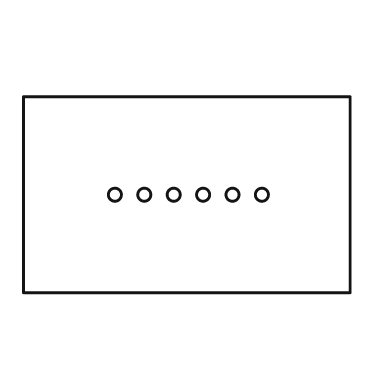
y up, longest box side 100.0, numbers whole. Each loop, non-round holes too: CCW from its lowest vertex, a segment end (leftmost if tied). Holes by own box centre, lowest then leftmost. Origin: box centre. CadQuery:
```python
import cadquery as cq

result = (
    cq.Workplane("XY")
    .moveTo(-50.0, -30.0)
    .lineTo(50.0, -30.0)
    .lineTo(50.0, 30.0)
    .lineTo(-50.0, 30.0)
    .close()
    .moveTo(-22.0, 0.0)
    .circle(2.0)
    .moveTo(-13.0, 0.0)
    .circle(2.0)
    .moveTo(-4.0, 0.0)
    .circle(2.0)
    .moveTo(5.0, 0.0)
    .circle(2.0)
    .moveTo(14.0, 0.0)
    .circle(2.0)
    .moveTo(23.0, 0.0)
    .circle(2.0)
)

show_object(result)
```